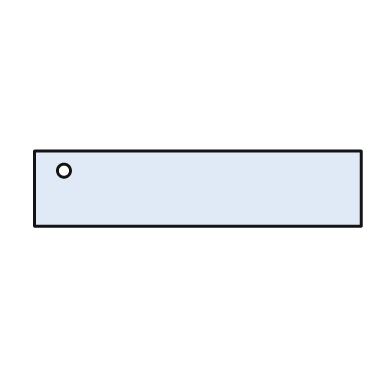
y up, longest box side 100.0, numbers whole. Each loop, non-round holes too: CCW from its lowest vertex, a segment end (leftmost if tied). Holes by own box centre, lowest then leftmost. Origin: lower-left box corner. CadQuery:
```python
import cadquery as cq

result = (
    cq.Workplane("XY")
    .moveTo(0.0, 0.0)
    .lineTo(100.0, 0.0)
    .lineTo(100.0, 23.0)
    .lineTo(0.0, 23.0)
    .close()
    .moveTo(9.0, 17.0)
    .circle(2.0)
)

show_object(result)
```